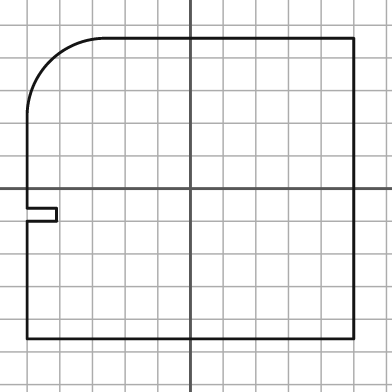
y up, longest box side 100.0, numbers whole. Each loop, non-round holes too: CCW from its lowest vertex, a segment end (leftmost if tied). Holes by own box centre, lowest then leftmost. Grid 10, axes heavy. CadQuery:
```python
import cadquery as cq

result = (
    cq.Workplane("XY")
    .moveTo(-50.0, -46.0)
    .lineTo(50.0, -46.0)
    .lineTo(50.0, 46.0)
    .lineTo(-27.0, 46.0)
    .threePointArc((-43.0, 39.0), (-50.0, 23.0))
    .lineTo(-50.0, -6.0)
    .lineTo(-41.0, -6.0)
    .lineTo(-41.0, -10.0)
    .lineTo(-50.0, -10.0)
    .close()
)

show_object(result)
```